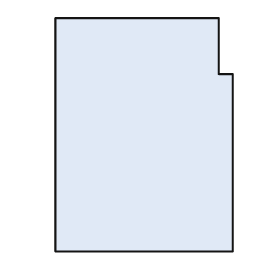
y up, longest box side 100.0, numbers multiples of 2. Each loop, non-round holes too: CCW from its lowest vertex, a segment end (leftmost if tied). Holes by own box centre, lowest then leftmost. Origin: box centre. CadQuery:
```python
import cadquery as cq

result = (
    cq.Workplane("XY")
    .moveTo(-38.0, -50.0)
    .lineTo(38.0, -50.0)
    .lineTo(38.0, 26.0)
    .lineTo(32.0, 26.0)
    .lineTo(32.0, 50.0)
    .lineTo(-38.0, 50.0)
    .close()
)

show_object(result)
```